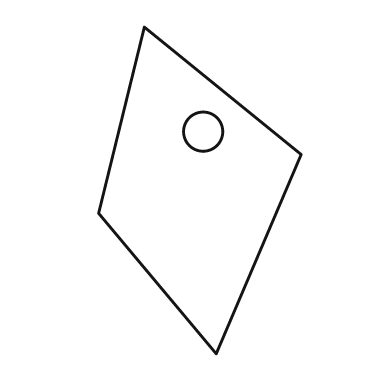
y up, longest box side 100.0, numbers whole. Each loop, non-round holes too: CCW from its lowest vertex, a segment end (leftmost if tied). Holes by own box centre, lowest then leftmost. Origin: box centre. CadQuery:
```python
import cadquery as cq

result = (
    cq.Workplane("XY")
    .moveTo(5.0, -50.0)
    .lineTo(31.0, 11.0)
    .lineTo(-17.0, 50.0)
    .lineTo(-31.0, -7.0)
    .close()
    .moveTo(1.0, 18.0)
    .circle(6.0)
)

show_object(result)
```